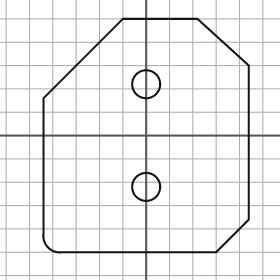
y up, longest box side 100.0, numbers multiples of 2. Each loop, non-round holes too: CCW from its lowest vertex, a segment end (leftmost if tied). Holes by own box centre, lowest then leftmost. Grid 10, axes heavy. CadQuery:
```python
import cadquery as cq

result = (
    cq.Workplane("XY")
    .moveTo(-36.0, -50.0)
    .lineTo(30.0, -50.0)
    .lineTo(44.0, -36.0)
    .lineTo(44.0, 30.0)
    .lineTo(22.0, 50.0)
    .lineTo(-10.0, 50.0)
    .lineTo(-44.0, 16.0)
    .lineTo(-44.0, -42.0)
    .threePointArc((-42.0, -48.0), (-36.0, -50.0))
    .close()
    .moveTo(0.0, -22.0)
    .circle(6.0)
    .moveTo(0.0, 22.0)
    .circle(6.0)
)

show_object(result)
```